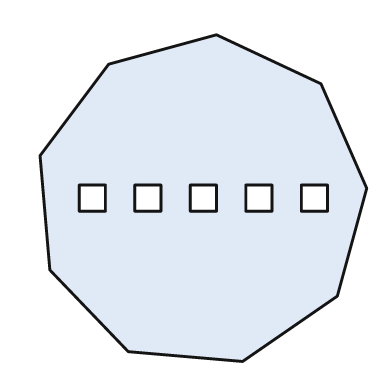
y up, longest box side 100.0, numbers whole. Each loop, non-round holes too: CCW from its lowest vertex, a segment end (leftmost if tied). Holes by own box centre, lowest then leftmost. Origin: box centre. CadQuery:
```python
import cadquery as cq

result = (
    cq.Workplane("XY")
    .moveTo(12.0, -50.0)
    .lineTo(41.0, -30.0)
    .lineTo(50.0, 3.0)
    .lineTo(36.0, 35.0)
    .lineTo(4.0, 50.0)
    .lineTo(-29.0, 41.0)
    .lineTo(-50.0, 13.0)
    .lineTo(-47.0, -22.0)
    .lineTo(-23.0, -47.0)
    .close()
    .moveTo(-38.0, -4.0)
    .lineTo(-30.0, -4.0)
    .lineTo(-30.0, 4.0)
    .lineTo(-38.0, 4.0)
    .close()
    .moveTo(-21.0, -4.0)
    .lineTo(-13.0, -4.0)
    .lineTo(-13.0, 4.0)
    .lineTo(-21.0, 4.0)
    .close()
    .moveTo(-4.0, -4.0)
    .lineTo(4.0, -4.0)
    .lineTo(4.0, 4.0)
    .lineTo(-4.0, 4.0)
    .close()
    .moveTo(13.0, -4.0)
    .lineTo(21.0, -4.0)
    .lineTo(21.0, 4.0)
    .lineTo(13.0, 4.0)
    .close()
    .moveTo(30.0, -4.0)
    .lineTo(38.0, -4.0)
    .lineTo(38.0, 4.0)
    .lineTo(30.0, 4.0)
    .close()
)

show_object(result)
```